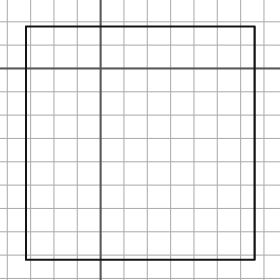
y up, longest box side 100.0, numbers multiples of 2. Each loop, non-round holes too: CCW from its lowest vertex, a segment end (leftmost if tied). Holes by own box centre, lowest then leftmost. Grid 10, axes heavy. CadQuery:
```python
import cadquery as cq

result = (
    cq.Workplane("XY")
    .moveTo(-32.0, -82.0)
    .lineTo(66.0, -82.0)
    .lineTo(66.0, 18.0)
    .lineTo(-32.0, 18.0)
    .close()
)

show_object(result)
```